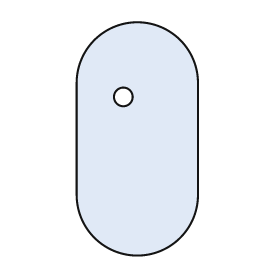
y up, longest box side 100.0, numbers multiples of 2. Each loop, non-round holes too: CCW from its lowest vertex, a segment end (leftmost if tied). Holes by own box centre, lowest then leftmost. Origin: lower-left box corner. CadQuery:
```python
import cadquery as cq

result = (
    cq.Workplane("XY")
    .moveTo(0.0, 26.0)
    .threePointArc((26.0, 0.0), (52.0, 26.0))
    .lineTo(52.0, 74.0)
    .threePointArc((26.0, 100.0), (0.0, 74.0))
    .close()
    .moveTo(20.0, 68.0)
    .circle(4.0)
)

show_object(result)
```